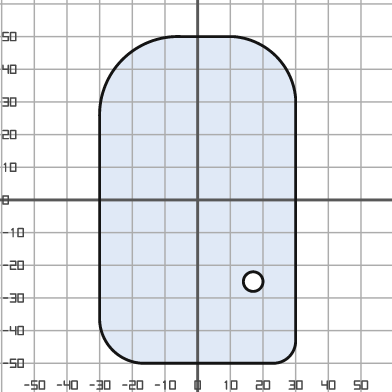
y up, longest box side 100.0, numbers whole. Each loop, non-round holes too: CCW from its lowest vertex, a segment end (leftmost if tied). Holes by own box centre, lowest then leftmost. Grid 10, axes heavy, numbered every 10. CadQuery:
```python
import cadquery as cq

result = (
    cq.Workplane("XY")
    .moveTo(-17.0, -50.0)
    .lineTo(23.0, -50.0)
    .threePointArc((28.0, -48.0), (30.0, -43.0))
    .lineTo(30.0, 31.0)
    .threePointArc((24.0, 44.0), (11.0, 50.0))
    .lineTo(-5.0, 50.0)
    .threePointArc((-23.0, 43.0), (-30.0, 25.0))
    .lineTo(-30.0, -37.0)
    .threePointArc((-26.0, -46.0), (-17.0, -50.0))
    .close()
    .moveTo(17.0, -25.0)
    .circle(3.0)
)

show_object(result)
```